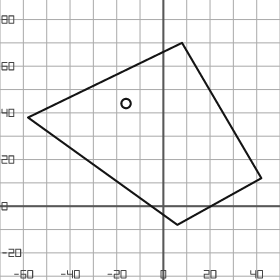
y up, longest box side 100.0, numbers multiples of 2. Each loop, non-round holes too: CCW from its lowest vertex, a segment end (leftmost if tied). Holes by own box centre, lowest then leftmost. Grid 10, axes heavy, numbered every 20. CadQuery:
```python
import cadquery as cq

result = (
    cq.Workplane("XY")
    .moveTo(6.0, -8.0)
    .lineTo(42.0, 12.0)
    .lineTo(8.0, 70.0)
    .lineTo(-58.0, 38.0)
    .close()
    .moveTo(-16.0, 44.0)
    .circle(2.0)
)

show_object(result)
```